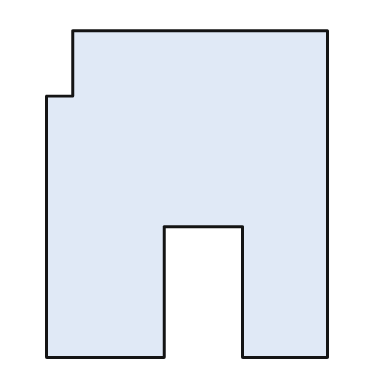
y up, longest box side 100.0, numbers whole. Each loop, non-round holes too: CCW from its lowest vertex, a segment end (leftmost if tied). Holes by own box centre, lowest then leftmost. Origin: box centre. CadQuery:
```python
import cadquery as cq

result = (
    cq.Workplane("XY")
    .moveTo(-43.0, -50.0)
    .lineTo(-7.0, -50.0)
    .lineTo(-7.0, -10.0)
    .lineTo(17.0, -10.0)
    .lineTo(17.0, -50.0)
    .lineTo(43.0, -50.0)
    .lineTo(43.0, 50.0)
    .lineTo(-35.0, 50.0)
    .lineTo(-35.0, 30.0)
    .lineTo(-43.0, 30.0)
    .close()
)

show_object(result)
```